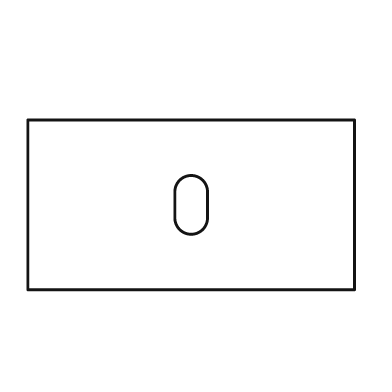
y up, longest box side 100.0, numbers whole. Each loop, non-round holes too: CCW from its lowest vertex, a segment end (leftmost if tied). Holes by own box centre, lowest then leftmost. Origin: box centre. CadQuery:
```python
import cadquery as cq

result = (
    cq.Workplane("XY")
    .moveTo(-50.0, -26.0)
    .lineTo(50.0, -26.0)
    .lineTo(50.0, 26.0)
    .lineTo(-50.0, 26.0)
    .close()
    .moveTo(-5.0, -4.0)
    .threePointArc((0.0, -9.0), (5.0, -4.0))
    .lineTo(5.0, 4.0)
    .threePointArc((0.0, 9.0), (-5.0, 4.0))
    .close()
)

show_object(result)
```